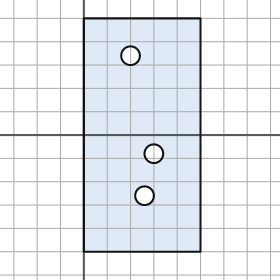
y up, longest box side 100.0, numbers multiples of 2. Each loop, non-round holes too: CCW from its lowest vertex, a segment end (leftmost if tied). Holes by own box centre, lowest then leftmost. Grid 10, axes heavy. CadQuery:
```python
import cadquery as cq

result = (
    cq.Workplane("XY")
    .moveTo(0.0, -50.0)
    .lineTo(50.0, -50.0)
    .lineTo(50.0, 50.0)
    .lineTo(0.0, 50.0)
    .close()
    .moveTo(26.0, -26.0)
    .circle(4.0)
    .moveTo(30.0, -8.0)
    .circle(4.0)
    .moveTo(20.0, 34.0)
    .circle(4.0)
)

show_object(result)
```